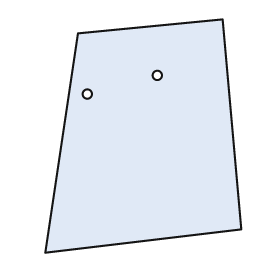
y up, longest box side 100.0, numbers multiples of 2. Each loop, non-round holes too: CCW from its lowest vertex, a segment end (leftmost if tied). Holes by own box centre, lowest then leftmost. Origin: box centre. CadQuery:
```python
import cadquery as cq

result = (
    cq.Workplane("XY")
    .moveTo(-42.0, -50.0)
    .lineTo(42.0, -40.0)
    .lineTo(34.0, 50.0)
    .lineTo(-28.0, 44.0)
    .close()
    .moveTo(-24.0, 18.0)
    .circle(2.0)
    .moveTo(6.0, 26.0)
    .circle(2.0)
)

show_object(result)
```